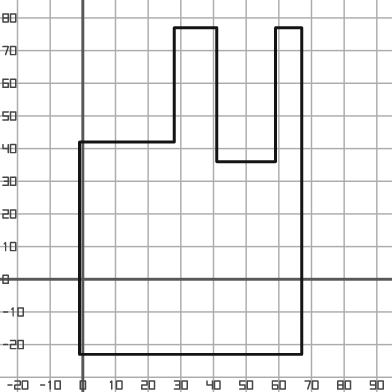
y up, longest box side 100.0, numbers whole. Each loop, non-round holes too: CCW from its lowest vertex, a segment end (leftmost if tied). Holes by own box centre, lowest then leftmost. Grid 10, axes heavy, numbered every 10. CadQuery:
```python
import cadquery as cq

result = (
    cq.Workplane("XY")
    .moveTo(-1.0, -23.0)
    .lineTo(67.0, -23.0)
    .lineTo(67.0, 77.0)
    .lineTo(59.0, 77.0)
    .lineTo(59.0, 36.0)
    .lineTo(41.0, 36.0)
    .lineTo(41.0, 77.0)
    .lineTo(28.0, 77.0)
    .lineTo(28.0, 42.0)
    .lineTo(-1.0, 42.0)
    .close()
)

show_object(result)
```